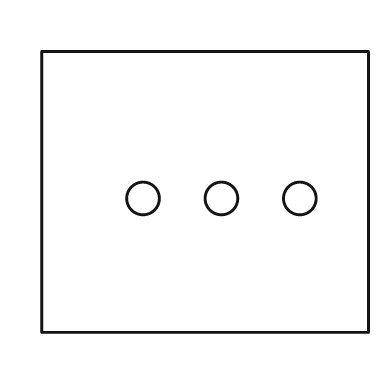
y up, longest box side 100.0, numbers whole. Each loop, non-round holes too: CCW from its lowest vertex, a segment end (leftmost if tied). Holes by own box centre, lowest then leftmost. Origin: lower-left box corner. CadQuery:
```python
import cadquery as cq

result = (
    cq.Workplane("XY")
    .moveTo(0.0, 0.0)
    .lineTo(100.0, 0.0)
    .lineTo(100.0, 86.0)
    .lineTo(0.0, 86.0)
    .close()
    .moveTo(31.0, 41.0)
    .circle(5.0)
    .moveTo(55.0, 41.0)
    .circle(5.0)
    .moveTo(79.0, 41.0)
    .circle(5.0)
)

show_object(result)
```